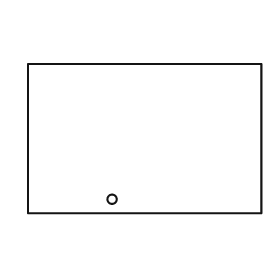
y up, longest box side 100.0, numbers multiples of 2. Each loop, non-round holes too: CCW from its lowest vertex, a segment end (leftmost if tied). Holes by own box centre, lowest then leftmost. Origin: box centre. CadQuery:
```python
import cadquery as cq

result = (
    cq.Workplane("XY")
    .moveTo(-50.0, -32.0)
    .lineTo(50.0, -32.0)
    .lineTo(50.0, 32.0)
    .lineTo(-50.0, 32.0)
    .close()
    .moveTo(-14.0, -26.0)
    .circle(2.0)
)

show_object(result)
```